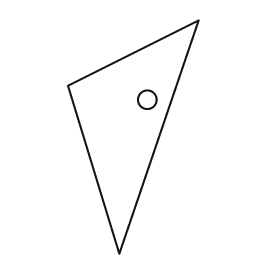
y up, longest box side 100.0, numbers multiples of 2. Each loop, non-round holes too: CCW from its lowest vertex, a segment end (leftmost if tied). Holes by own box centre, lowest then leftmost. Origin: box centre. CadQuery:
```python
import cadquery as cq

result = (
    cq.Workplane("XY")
    .moveTo(-6.0, -50.0)
    .lineTo(28.0, 50.0)
    .lineTo(-28.0, 22.0)
    .close()
    .moveTo(6.0, 16.0)
    .circle(4.0)
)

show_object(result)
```